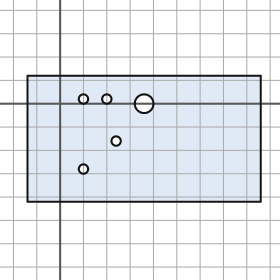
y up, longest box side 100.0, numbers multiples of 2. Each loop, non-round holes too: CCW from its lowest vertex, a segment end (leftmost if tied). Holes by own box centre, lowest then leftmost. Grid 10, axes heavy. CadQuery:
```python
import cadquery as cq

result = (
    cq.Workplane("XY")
    .moveTo(-14.0, -42.0)
    .lineTo(86.0, -42.0)
    .lineTo(86.0, 12.0)
    .lineTo(-14.0, 12.0)
    .close()
    .moveTo(10.0, -28.0)
    .circle(2.0)
    .moveTo(24.0, -16.0)
    .circle(2.0)
    .moveTo(36.0, 0.0)
    .circle(4.0)
    .moveTo(10.0, 2.0)
    .circle(2.0)
    .moveTo(20.0, 2.0)
    .circle(2.0)
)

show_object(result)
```